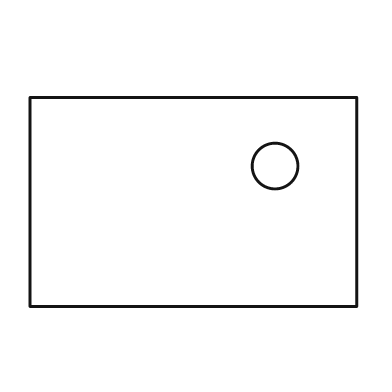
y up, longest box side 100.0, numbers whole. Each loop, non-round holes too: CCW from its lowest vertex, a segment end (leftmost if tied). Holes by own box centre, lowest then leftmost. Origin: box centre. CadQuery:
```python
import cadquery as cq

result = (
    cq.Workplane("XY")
    .moveTo(-50.0, -32.0)
    .lineTo(50.0, -32.0)
    .lineTo(50.0, 32.0)
    .lineTo(-50.0, 32.0)
    .close()
    .moveTo(25.0, 11.0)
    .circle(7.0)
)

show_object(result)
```